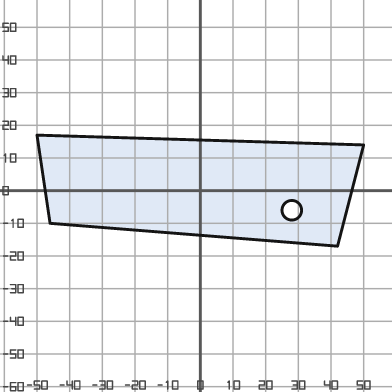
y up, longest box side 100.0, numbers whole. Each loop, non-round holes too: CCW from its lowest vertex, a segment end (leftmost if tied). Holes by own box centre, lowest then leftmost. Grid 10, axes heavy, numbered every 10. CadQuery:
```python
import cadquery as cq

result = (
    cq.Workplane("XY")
    .moveTo(42.0, -17.0)
    .lineTo(50.0, 14.0)
    .lineTo(-50.0, 17.0)
    .lineTo(-46.0, -10.0)
    .close()
    .moveTo(28.0, -6.0)
    .circle(3.0)
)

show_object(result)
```